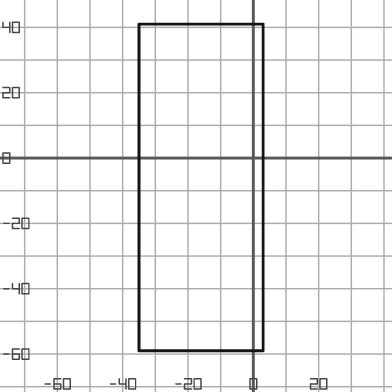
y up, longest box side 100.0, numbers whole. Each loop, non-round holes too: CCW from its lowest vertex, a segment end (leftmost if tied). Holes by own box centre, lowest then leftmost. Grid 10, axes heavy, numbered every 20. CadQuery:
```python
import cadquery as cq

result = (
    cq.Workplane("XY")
    .moveTo(-35.0, -59.0)
    .lineTo(3.0, -59.0)
    .lineTo(3.0, 41.0)
    .lineTo(-35.0, 41.0)
    .close()
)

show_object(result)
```